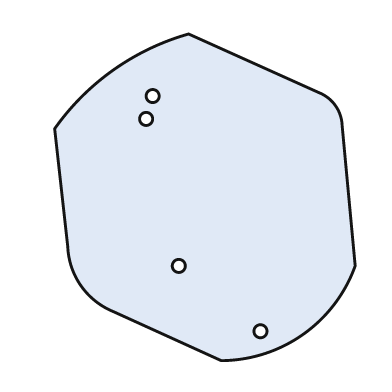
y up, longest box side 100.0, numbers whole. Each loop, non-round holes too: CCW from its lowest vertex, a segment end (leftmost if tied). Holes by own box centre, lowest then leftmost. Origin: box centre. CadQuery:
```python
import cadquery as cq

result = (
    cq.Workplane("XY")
    .moveTo(5.0, -50.0)
    .threePointArc((30.0, -42.0), (46.0, -21.0))
    .lineTo(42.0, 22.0)
    .threePointArc((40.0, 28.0), (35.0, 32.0))
    .lineTo(-5.0, 50.0)
    .threePointArc((-28.0, 39.0), (-46.0, 21.0))
    .lineTo(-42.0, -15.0)
    .threePointArc((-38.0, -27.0), (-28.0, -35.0))
    .close()
    .moveTo(17.0, -41.0)
    .circle(2.0)
    .moveTo(-8.0, -21.0)
    .circle(2.0)
    .moveTo(-18.0, 24.0)
    .circle(2.0)
    .moveTo(-16.0, 31.0)
    .circle(2.0)
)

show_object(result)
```